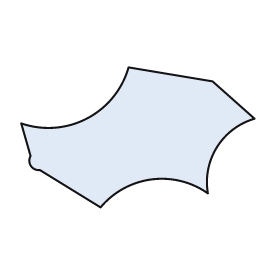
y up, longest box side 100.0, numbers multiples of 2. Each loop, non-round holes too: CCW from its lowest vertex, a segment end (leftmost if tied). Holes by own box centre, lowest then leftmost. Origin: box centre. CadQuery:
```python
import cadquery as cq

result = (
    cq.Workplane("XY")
    .moveTo(-16.0, -30.0)
    .threePointArc((6.0, -18.0), (30.0, -24.0))
    .threePointArc((34.0, -4.0), (50.0, 8.0))
    .lineTo(32.0, 24.0)
    .lineTo(-4.0, 30.0)
    .threePointArc((-22.0, 8.0), (-50.0, 6.0))
    .lineTo(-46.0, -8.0)
    .threePointArc((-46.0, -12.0), (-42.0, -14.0))
    .close()
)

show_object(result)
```